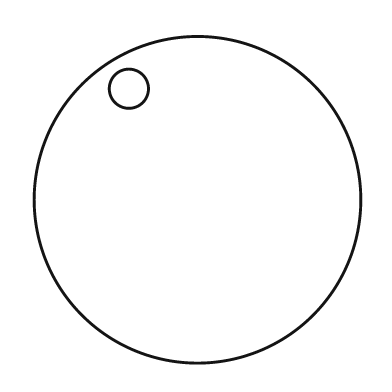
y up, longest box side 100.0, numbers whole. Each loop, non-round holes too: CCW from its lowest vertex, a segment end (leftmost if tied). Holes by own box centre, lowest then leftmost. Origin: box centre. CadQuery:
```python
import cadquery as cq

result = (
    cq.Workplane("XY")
    .moveTo(0.0, 0.0)
    .circle(50.0)
    .moveTo(-21.0, 34.0)
    .circle(6.0)
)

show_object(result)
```